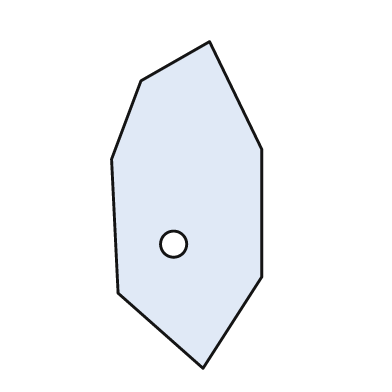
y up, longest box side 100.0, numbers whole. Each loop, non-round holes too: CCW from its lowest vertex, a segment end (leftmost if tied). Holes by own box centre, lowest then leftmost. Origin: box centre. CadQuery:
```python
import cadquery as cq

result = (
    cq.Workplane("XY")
    .moveTo(5.0, -50.0)
    .lineTo(23.0, -22.0)
    .lineTo(23.0, 17.0)
    .lineTo(7.0, 50.0)
    .lineTo(-14.0, 38.0)
    .lineTo(-23.0, 14.0)
    .lineTo(-21.0, -27.0)
    .close()
    .moveTo(-4.0, -12.0)
    .circle(4.0)
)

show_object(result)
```